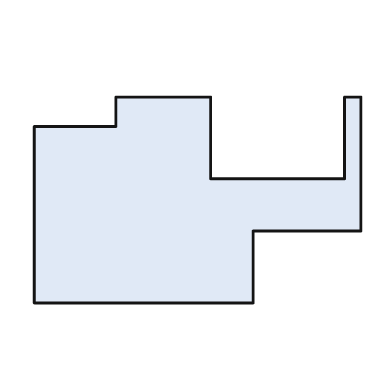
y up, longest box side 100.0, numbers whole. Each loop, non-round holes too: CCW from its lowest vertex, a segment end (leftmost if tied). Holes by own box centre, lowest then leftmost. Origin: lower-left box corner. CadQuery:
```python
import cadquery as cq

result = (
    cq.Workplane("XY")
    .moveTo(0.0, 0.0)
    .lineTo(67.0, 0.0)
    .lineTo(67.0, 22.0)
    .lineTo(100.0, 22.0)
    .lineTo(100.0, 63.0)
    .lineTo(95.0, 63.0)
    .lineTo(95.0, 38.0)
    .lineTo(54.0, 38.0)
    .lineTo(54.0, 63.0)
    .lineTo(25.0, 63.0)
    .lineTo(25.0, 54.0)
    .lineTo(0.0, 54.0)
    .close()
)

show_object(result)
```